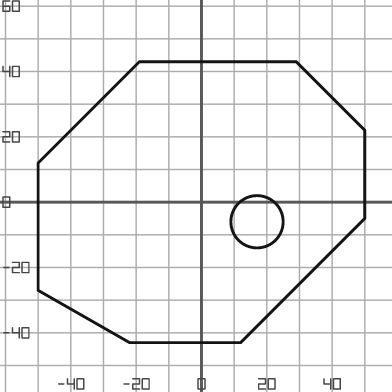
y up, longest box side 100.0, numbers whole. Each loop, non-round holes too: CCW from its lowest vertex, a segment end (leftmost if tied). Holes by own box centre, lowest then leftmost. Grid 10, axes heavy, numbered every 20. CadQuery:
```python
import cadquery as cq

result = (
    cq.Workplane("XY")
    .moveTo(-22.0, -43.0)
    .lineTo(12.0, -43.0)
    .lineTo(50.0, -5.0)
    .lineTo(50.0, 22.0)
    .lineTo(29.0, 43.0)
    .lineTo(-19.0, 43.0)
    .lineTo(-50.0, 12.0)
    .lineTo(-50.0, -27.0)
    .close()
    .moveTo(17.0, -6.0)
    .circle(8.0)
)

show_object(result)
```